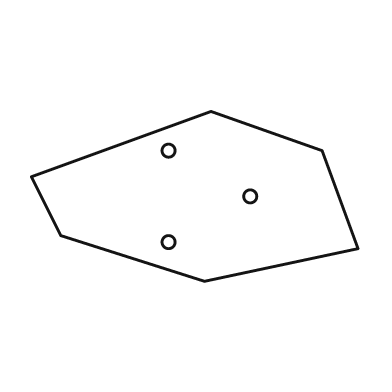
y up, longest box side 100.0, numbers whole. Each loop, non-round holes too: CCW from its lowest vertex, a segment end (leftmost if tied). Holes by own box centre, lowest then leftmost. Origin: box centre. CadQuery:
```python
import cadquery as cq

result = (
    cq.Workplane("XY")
    .moveTo(3.0, -26.0)
    .lineTo(50.0, -16.0)
    .lineTo(39.0, 14.0)
    .lineTo(5.0, 26.0)
    .lineTo(-50.0, 6.0)
    .lineTo(-41.0, -12.0)
    .close()
    .moveTo(-8.0, -14.0)
    .circle(2.0)
    .moveTo(17.0, 0.0)
    .circle(2.0)
    .moveTo(-8.0, 14.0)
    .circle(2.0)
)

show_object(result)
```